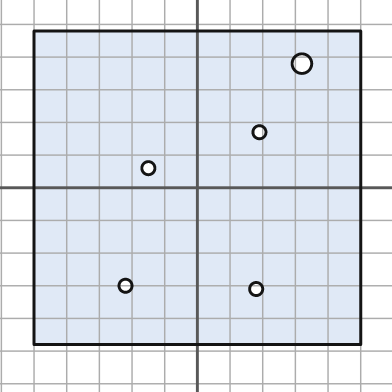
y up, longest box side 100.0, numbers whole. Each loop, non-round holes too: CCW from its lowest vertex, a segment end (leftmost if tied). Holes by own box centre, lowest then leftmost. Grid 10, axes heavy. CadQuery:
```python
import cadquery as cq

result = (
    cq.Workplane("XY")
    .moveTo(-50.0, -48.0)
    .lineTo(50.0, -48.0)
    .lineTo(50.0, 48.0)
    .lineTo(-50.0, 48.0)
    .close()
    .moveTo(18.0, -31.0)
    .circle(2.0)
    .moveTo(-22.0, -30.0)
    .circle(2.0)
    .moveTo(-15.0, 6.0)
    .circle(2.0)
    .moveTo(19.0, 17.0)
    .circle(2.0)
    .moveTo(32.0, 38.0)
    .circle(3.0)
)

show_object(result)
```